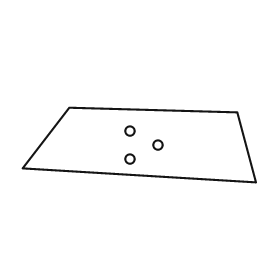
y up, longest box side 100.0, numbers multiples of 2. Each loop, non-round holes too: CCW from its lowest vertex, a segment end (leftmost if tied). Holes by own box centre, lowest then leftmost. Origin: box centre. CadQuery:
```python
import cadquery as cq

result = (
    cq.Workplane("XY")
    .moveTo(50.0, -16.0)
    .lineTo(42.0, 14.0)
    .lineTo(-30.0, 16.0)
    .lineTo(-50.0, -10.0)
    .close()
    .moveTo(-4.0, -6.0)
    .circle(2.0)
    .moveTo(8.0, 0.0)
    .circle(2.0)
    .moveTo(-4.0, 6.0)
    .circle(2.0)
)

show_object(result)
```